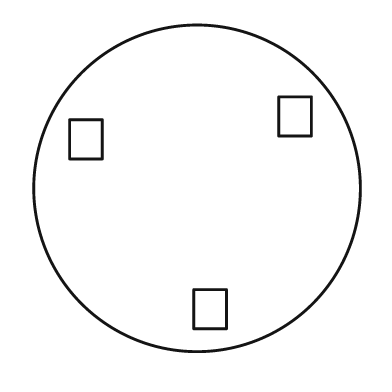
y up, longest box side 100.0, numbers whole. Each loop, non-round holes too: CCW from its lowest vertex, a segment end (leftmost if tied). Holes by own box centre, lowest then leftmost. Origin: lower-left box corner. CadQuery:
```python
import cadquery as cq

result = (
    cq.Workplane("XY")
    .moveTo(50.0, 50.0)
    .circle(50.0)
    .moveTo(49.0, 7.0)
    .lineTo(59.0, 7.0)
    .lineTo(59.0, 19.0)
    .lineTo(49.0, 19.0)
    .close()
    .moveTo(11.0, 59.0)
    .lineTo(21.0, 59.0)
    .lineTo(21.0, 71.0)
    .lineTo(11.0, 71.0)
    .close()
    .moveTo(75.0, 66.0)
    .lineTo(85.0, 66.0)
    .lineTo(85.0, 78.0)
    .lineTo(75.0, 78.0)
    .close()
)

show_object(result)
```